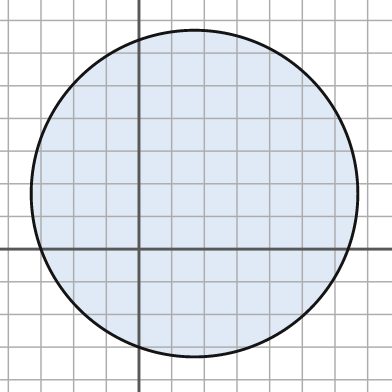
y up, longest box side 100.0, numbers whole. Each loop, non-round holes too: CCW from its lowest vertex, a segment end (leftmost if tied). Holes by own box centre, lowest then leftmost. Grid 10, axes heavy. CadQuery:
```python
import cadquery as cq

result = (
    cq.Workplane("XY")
    .moveTo(17.0, 17.0)
    .circle(50.0)
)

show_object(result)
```